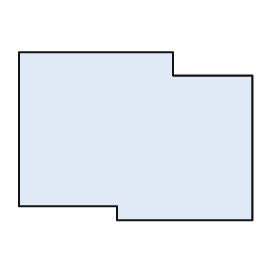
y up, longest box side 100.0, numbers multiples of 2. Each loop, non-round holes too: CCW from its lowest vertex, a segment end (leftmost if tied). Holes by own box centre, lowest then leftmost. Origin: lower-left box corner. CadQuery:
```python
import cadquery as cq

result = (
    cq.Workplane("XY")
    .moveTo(42.0, 0.0)
    .lineTo(100.0, 0.0)
    .lineTo(100.0, 62.0)
    .lineTo(66.0, 62.0)
    .lineTo(66.0, 72.0)
    .lineTo(0.0, 72.0)
    .lineTo(0.0, 6.0)
    .lineTo(42.0, 6.0)
    .close()
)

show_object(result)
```